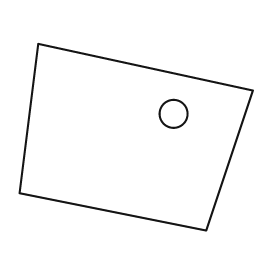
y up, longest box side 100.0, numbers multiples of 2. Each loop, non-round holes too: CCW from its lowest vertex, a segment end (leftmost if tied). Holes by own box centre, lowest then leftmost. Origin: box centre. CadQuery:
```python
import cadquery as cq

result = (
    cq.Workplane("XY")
    .moveTo(30.0, -40.0)
    .lineTo(50.0, 20.0)
    .lineTo(-42.0, 40.0)
    .lineTo(-50.0, -24.0)
    .close()
    .moveTo(16.0, 10.0)
    .circle(6.0)
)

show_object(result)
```